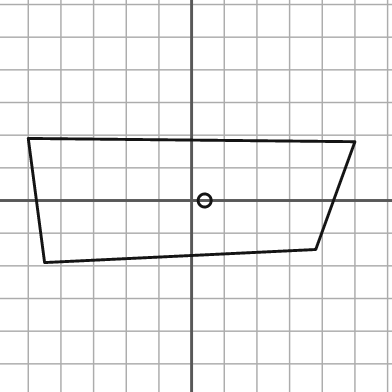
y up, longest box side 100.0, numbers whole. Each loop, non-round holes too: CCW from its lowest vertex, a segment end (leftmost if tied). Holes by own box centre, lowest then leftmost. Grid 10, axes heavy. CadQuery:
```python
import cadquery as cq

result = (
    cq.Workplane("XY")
    .moveTo(-45.0, -19.0)
    .lineTo(38.0, -15.0)
    .lineTo(50.0, 18.0)
    .lineTo(-50.0, 19.0)
    .close()
    .moveTo(4.0, 0.0)
    .circle(2.0)
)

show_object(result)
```